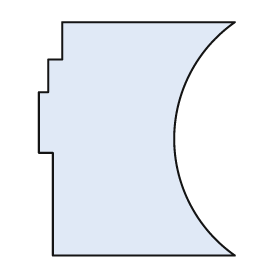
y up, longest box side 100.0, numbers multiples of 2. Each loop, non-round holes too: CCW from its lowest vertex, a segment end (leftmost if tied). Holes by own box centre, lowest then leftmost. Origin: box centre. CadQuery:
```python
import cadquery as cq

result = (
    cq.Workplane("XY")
    .moveTo(-36.0, -50.0)
    .lineTo(42.0, -50.0)
    .threePointArc((16.0, 0.0), (42.0, 50.0))
    .lineTo(-32.0, 50.0)
    .lineTo(-32.0, 34.0)
    .lineTo(-38.0, 34.0)
    .lineTo(-38.0, 20.0)
    .lineTo(-42.0, 20.0)
    .lineTo(-42.0, -6.0)
    .lineTo(-36.0, -6.0)
    .close()
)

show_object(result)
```